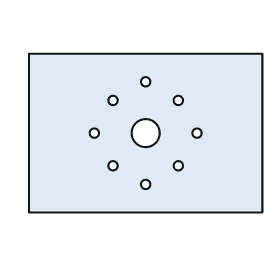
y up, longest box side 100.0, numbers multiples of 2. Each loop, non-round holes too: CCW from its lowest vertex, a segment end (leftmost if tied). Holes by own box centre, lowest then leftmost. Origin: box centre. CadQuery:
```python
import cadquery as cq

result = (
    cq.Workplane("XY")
    .moveTo(-50.0, -34.0)
    .lineTo(50.0, -34.0)
    .lineTo(50.0, 34.0)
    .lineTo(-50.0, 34.0)
    .close()
    .moveTo(0.0, -22.0)
    .circle(2.0)
    .moveTo(-14.0, -14.0)
    .circle(2.0)
    .moveTo(14.0, -14.0)
    .circle(2.0)
    .moveTo(-22.0, 0.0)
    .circle(2.0)
    .moveTo(0.0, 0.0)
    .circle(6.0)
    .moveTo(22.0, 0.0)
    .circle(2.0)
    .moveTo(-14.0, 14.0)
    .circle(2.0)
    .moveTo(14.0, 14.0)
    .circle(2.0)
    .moveTo(0.0, 22.0)
    .circle(2.0)
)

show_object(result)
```